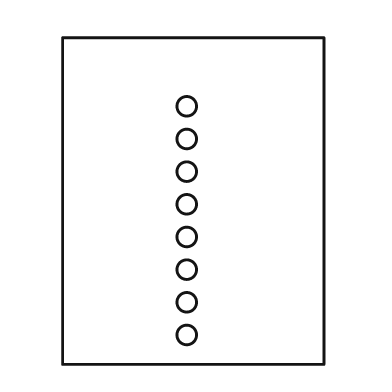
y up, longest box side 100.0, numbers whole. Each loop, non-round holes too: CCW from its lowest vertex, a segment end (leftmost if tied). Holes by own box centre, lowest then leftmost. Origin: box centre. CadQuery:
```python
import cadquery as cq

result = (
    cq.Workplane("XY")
    .moveTo(-40.0, -50.0)
    .lineTo(40.0, -50.0)
    .lineTo(40.0, 50.0)
    .lineTo(-40.0, 50.0)
    .close()
    .moveTo(-2.0, -41.0)
    .circle(3.0)
    .moveTo(-2.0, -31.0)
    .circle(3.0)
    .moveTo(-2.0, -21.0)
    .circle(3.0)
    .moveTo(-2.0, -11.0)
    .circle(3.0)
    .moveTo(-2.0, -1.0)
    .circle(3.0)
    .moveTo(-2.0, 9.0)
    .circle(3.0)
    .moveTo(-2.0, 19.0)
    .circle(3.0)
    .moveTo(-2.0, 29.0)
    .circle(3.0)
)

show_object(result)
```